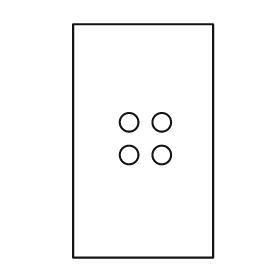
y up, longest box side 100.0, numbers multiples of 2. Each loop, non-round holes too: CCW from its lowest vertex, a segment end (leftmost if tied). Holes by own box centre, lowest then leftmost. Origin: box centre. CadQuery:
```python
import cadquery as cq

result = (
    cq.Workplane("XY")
    .moveTo(-30.0, -50.0)
    .lineTo(30.0, -50.0)
    .lineTo(30.0, 50.0)
    .lineTo(-30.0, 50.0)
    .close()
    .moveTo(-6.0, -6.0)
    .circle(4.0)
    .moveTo(8.0, -6.0)
    .circle(4.0)
    .moveTo(-6.0, 8.0)
    .circle(4.0)
    .moveTo(8.0, 8.0)
    .circle(4.0)
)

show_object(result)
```